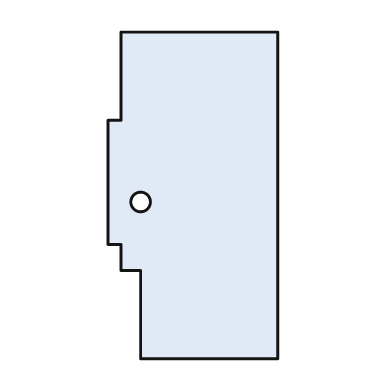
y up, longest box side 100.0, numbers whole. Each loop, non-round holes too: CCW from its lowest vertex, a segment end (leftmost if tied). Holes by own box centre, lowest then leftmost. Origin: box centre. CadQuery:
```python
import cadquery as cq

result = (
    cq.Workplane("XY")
    .moveTo(-16.0, -50.0)
    .lineTo(26.0, -50.0)
    .lineTo(26.0, 50.0)
    .lineTo(-22.0, 50.0)
    .lineTo(-22.0, 23.0)
    .lineTo(-26.0, 23.0)
    .lineTo(-26.0, -15.0)
    .lineTo(-22.0, -15.0)
    .lineTo(-22.0, -23.0)
    .lineTo(-16.0, -23.0)
    .close()
    .moveTo(-16.0, -2.0)
    .circle(3.0)
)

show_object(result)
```